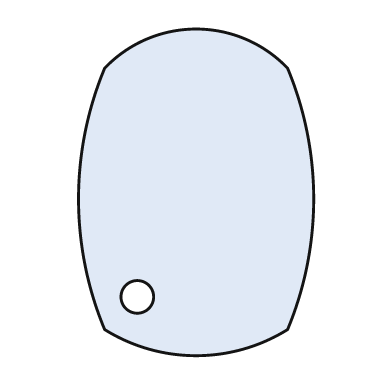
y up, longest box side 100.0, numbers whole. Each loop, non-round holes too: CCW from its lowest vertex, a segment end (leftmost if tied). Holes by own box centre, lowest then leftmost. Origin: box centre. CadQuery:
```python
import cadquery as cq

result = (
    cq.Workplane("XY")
    .moveTo(-28.0, -42.0)
    .threePointArc((0.0, -50.0), (28.0, -42.0))
    .threePointArc((36.0, -2.0), (28.0, 38.0))
    .threePointArc((0.0, 50.0), (-28.0, 38.0))
    .threePointArc((-36.0, -2.0), (-28.0, -42.0))
    .close()
    .moveTo(-18.0, -32.0)
    .circle(5.0)
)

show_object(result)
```